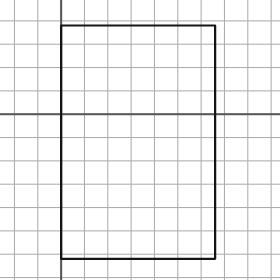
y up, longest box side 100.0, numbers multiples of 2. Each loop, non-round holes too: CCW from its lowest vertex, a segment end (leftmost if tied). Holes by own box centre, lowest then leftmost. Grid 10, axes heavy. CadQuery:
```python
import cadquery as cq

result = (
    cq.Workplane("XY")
    .moveTo(0.0, -62.0)
    .lineTo(66.0, -62.0)
    .lineTo(66.0, 38.0)
    .lineTo(0.0, 38.0)
    .close()
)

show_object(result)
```